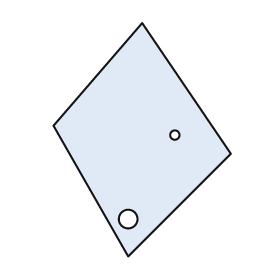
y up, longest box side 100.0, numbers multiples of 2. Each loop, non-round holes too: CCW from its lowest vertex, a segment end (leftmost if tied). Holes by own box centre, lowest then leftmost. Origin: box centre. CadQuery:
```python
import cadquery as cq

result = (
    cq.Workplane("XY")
    .moveTo(-6.0, -50.0)
    .lineTo(38.0, -6.0)
    .lineTo(0.0, 50.0)
    .lineTo(-38.0, 6.0)
    .close()
    .moveTo(-6.0, -34.0)
    .circle(4.0)
    .moveTo(14.0, 2.0)
    .circle(2.0)
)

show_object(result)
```